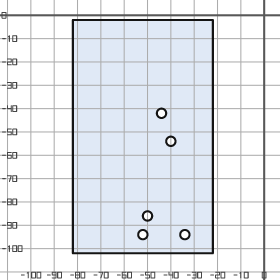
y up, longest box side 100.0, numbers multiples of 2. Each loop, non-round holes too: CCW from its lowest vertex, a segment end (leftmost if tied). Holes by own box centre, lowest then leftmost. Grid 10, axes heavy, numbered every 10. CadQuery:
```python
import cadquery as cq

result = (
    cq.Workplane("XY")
    .moveTo(-82.0, -102.0)
    .lineTo(-22.0, -102.0)
    .lineTo(-22.0, -2.0)
    .lineTo(-82.0, -2.0)
    .close()
    .moveTo(-52.0, -94.0)
    .circle(2.0)
    .moveTo(-34.0, -94.0)
    .circle(2.0)
    .moveTo(-50.0, -86.0)
    .circle(2.0)
    .moveTo(-40.0, -54.0)
    .circle(2.0)
    .moveTo(-44.0, -42.0)
    .circle(2.0)
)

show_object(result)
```